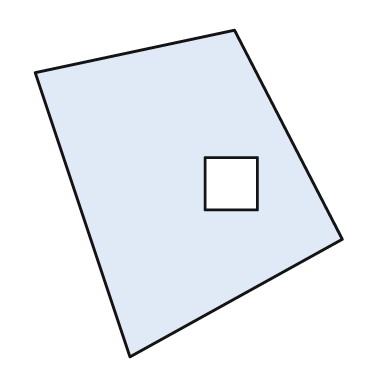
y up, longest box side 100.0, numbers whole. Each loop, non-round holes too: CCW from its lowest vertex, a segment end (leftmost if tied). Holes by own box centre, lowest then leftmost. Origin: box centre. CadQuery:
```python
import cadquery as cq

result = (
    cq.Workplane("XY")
    .moveTo(-18.0, -50.0)
    .lineTo(47.0, -14.0)
    .lineTo(14.0, 50.0)
    .lineTo(-47.0, 37.0)
    .close()
    .moveTo(5.0, -5.0)
    .lineTo(21.0, -5.0)
    .lineTo(21.0, 11.0)
    .lineTo(5.0, 11.0)
    .close()
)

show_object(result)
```